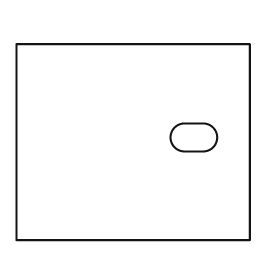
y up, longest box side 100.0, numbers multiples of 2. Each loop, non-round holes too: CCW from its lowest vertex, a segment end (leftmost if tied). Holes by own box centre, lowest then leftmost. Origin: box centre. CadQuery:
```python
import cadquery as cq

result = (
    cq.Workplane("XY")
    .moveTo(-50.0, -42.0)
    .lineTo(50.0, -42.0)
    .lineTo(50.0, 42.0)
    .lineTo(-50.0, 42.0)
    .close()
    .moveTo(22.0, -4.0)
    .lineTo(30.0, -4.0)
    .threePointArc((36.0, 2.0), (30.0, 8.0))
    .lineTo(22.0, 8.0)
    .threePointArc((16.0, 2.0), (22.0, -4.0))
    .close()
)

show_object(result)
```